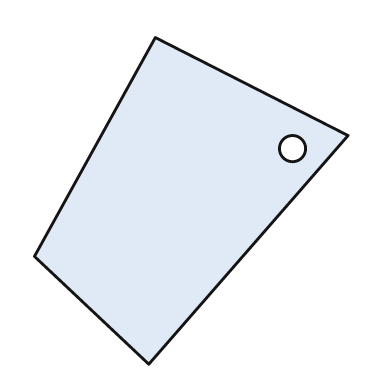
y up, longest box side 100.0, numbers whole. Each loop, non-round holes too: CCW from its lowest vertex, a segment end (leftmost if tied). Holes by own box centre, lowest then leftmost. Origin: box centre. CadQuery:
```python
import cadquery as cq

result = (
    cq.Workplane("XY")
    .moveTo(-13.0, -50.0)
    .lineTo(48.0, 20.0)
    .lineTo(-11.0, 50.0)
    .lineTo(-48.0, -17.0)
    .close()
    .moveTo(31.0, 16.0)
    .circle(4.0)
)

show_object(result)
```